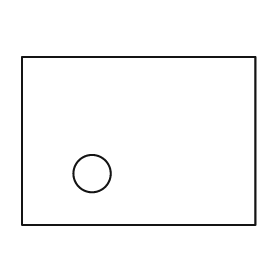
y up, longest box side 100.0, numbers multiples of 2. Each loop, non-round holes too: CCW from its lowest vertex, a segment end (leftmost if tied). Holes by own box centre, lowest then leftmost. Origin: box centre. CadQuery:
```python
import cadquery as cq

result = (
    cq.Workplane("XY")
    .moveTo(-50.0, -36.0)
    .lineTo(50.0, -36.0)
    .lineTo(50.0, 36.0)
    .lineTo(-50.0, 36.0)
    .close()
    .moveTo(-20.0, -14.0)
    .circle(8.0)
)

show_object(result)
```